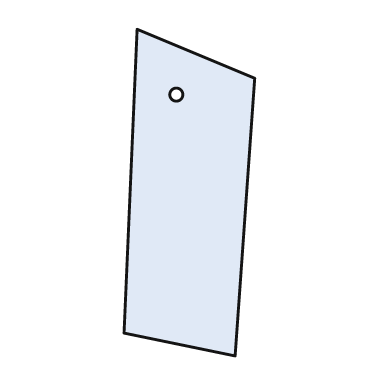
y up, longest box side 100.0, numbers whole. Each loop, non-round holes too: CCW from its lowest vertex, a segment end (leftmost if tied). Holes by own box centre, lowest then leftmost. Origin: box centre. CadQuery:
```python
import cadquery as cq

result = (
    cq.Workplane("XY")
    .moveTo(14.0, -50.0)
    .lineTo(20.0, 35.0)
    .lineTo(-16.0, 50.0)
    .lineTo(-20.0, -43.0)
    .close()
    .moveTo(-4.0, 30.0)
    .circle(2.0)
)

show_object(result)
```